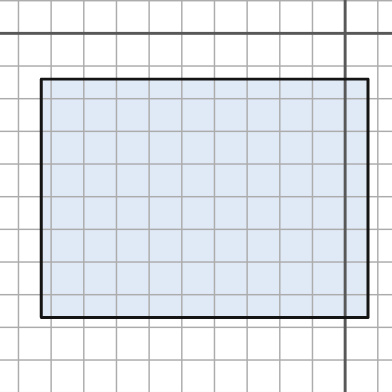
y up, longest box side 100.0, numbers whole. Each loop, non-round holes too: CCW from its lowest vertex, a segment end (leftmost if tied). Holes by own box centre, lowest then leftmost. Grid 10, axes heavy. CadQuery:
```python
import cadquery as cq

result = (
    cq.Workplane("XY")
    .moveTo(-93.0, -87.0)
    .lineTo(7.0, -87.0)
    .lineTo(7.0, -14.0)
    .lineTo(-93.0, -14.0)
    .close()
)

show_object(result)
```